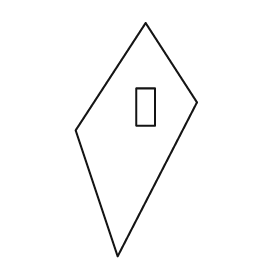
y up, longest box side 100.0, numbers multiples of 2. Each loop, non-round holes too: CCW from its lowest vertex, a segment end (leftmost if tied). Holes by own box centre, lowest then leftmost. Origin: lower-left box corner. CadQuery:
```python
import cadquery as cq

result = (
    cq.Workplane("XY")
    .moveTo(18.0, 0.0)
    .lineTo(52.0, 66.0)
    .lineTo(30.0, 100.0)
    .lineTo(0.0, 54.0)
    .close()
    .moveTo(26.0, 56.0)
    .lineTo(34.0, 56.0)
    .lineTo(34.0, 72.0)
    .lineTo(26.0, 72.0)
    .close()
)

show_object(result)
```